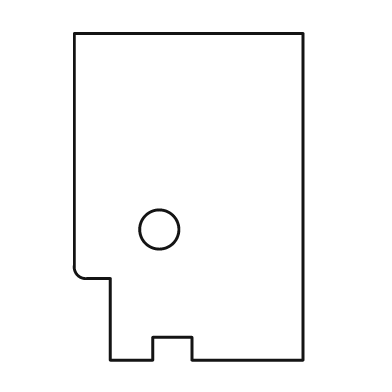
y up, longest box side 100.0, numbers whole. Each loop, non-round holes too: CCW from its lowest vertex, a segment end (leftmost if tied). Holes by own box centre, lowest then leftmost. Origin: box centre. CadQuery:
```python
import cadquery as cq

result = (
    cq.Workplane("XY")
    .moveTo(-24.0, -50.0)
    .lineTo(-11.0, -50.0)
    .lineTo(-11.0, -43.0)
    .lineTo(1.0, -43.0)
    .lineTo(1.0, -50.0)
    .lineTo(35.0, -50.0)
    .lineTo(35.0, 50.0)
    .lineTo(-35.0, 50.0)
    .lineTo(-35.0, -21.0)
    .threePointArc((-34.0, -24.0), (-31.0, -25.0))
    .lineTo(-24.0, -25.0)
    .close()
    .moveTo(-9.0, -10.0)
    .circle(6.0)
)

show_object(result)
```